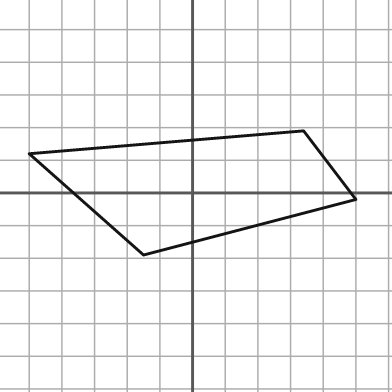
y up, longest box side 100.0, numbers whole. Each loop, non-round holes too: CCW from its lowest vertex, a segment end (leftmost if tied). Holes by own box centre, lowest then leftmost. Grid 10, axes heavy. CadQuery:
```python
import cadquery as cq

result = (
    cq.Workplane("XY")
    .moveTo(-15.0, -19.0)
    .lineTo(50.0, -2.0)
    .lineTo(34.0, 19.0)
    .lineTo(-50.0, 12.0)
    .close()
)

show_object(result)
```